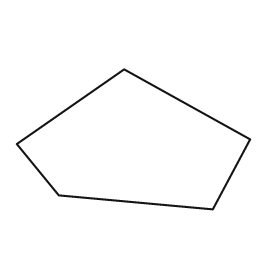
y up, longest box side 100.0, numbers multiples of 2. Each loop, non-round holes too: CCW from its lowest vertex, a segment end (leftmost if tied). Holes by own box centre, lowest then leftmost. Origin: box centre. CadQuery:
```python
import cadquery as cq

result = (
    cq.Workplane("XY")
    .moveTo(34.0, -30.0)
    .lineTo(50.0, 0.0)
    .lineTo(-4.0, 30.0)
    .lineTo(-50.0, -2.0)
    .lineTo(-32.0, -24.0)
    .close()
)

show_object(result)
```